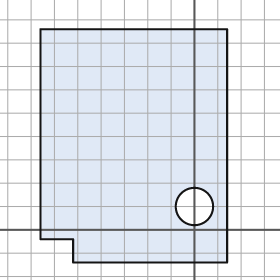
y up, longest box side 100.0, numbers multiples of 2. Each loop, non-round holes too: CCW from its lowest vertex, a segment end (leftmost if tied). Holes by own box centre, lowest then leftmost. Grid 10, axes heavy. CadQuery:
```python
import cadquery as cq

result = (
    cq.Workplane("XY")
    .moveTo(-52.0, -14.0)
    .lineTo(14.0, -14.0)
    .lineTo(14.0, 86.0)
    .lineTo(-66.0, 86.0)
    .lineTo(-66.0, -4.0)
    .lineTo(-52.0, -4.0)
    .close()
    .moveTo(0.0, 10.0)
    .circle(8.0)
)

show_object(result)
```